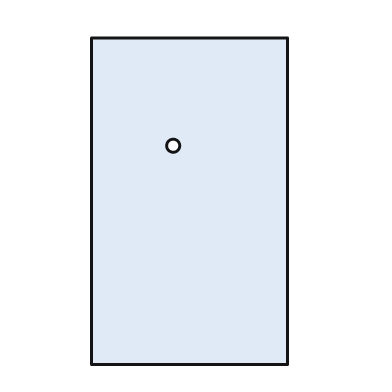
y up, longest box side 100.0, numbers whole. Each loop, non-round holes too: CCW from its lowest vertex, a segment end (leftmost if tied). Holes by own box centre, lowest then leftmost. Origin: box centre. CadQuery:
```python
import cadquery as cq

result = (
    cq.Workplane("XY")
    .moveTo(-30.0, -50.0)
    .lineTo(30.0, -50.0)
    .lineTo(30.0, 50.0)
    .lineTo(-30.0, 50.0)
    .close()
    .moveTo(-5.0, 17.0)
    .circle(2.0)
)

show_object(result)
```